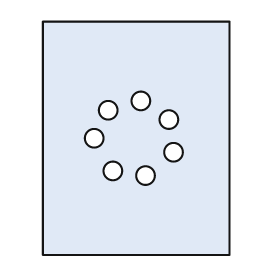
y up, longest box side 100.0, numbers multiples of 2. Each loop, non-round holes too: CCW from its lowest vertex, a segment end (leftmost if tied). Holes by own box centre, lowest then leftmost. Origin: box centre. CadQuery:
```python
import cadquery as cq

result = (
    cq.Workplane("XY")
    .moveTo(-40.0, -50.0)
    .lineTo(40.0, -50.0)
    .lineTo(40.0, 50.0)
    .lineTo(-40.0, 50.0)
    .close()
    .moveTo(4.0, -16.0)
    .circle(4.0)
    .moveTo(-10.0, -14.0)
    .circle(4.0)
    .moveTo(16.0, -6.0)
    .circle(4.0)
    .moveTo(-18.0, 0.0)
    .circle(4.0)
    .moveTo(14.0, 8.0)
    .circle(4.0)
    .moveTo(-12.0, 12.0)
    .circle(4.0)
    .moveTo(2.0, 16.0)
    .circle(4.0)
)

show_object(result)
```